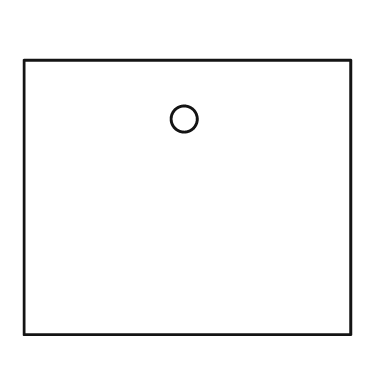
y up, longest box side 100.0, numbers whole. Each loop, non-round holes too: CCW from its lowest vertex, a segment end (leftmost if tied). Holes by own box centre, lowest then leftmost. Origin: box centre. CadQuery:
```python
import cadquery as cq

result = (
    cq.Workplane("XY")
    .moveTo(-50.0, -42.0)
    .lineTo(50.0, -42.0)
    .lineTo(50.0, 42.0)
    .lineTo(-50.0, 42.0)
    .close()
    .moveTo(-1.0, 24.0)
    .circle(4.0)
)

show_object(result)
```